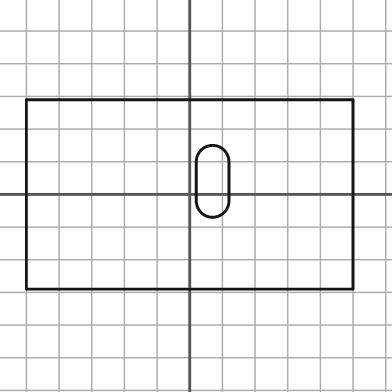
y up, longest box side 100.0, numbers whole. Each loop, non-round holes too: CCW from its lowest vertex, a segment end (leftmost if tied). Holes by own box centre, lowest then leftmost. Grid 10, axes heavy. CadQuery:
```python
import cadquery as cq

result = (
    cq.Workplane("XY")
    .moveTo(-50.0, -29.0)
    .lineTo(50.0, -29.0)
    .lineTo(50.0, 29.0)
    .lineTo(-50.0, 29.0)
    .close()
    .moveTo(2.0, -2.0)
    .threePointArc((7.0, -7.0), (12.0, -2.0))
    .lineTo(12.0, 10.0)
    .threePointArc((7.0, 15.0), (2.0, 10.0))
    .close()
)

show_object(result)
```